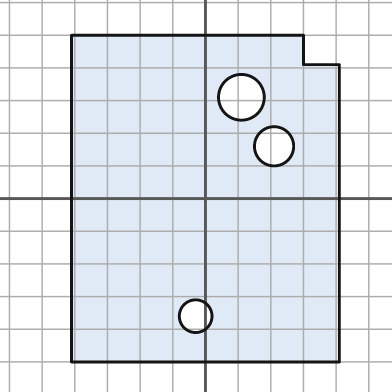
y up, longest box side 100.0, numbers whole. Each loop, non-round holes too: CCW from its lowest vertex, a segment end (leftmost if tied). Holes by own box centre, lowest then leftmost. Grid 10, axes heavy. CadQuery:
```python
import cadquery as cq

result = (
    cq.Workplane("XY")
    .moveTo(-41.0, -50.0)
    .lineTo(41.0, -50.0)
    .lineTo(41.0, 41.0)
    .lineTo(30.0, 41.0)
    .lineTo(30.0, 50.0)
    .lineTo(-41.0, 50.0)
    .close()
    .moveTo(-3.0, -36.0)
    .circle(5.0)
    .moveTo(21.0, 16.0)
    .circle(6.0)
    .moveTo(11.0, 31.0)
    .circle(7.0)
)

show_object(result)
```